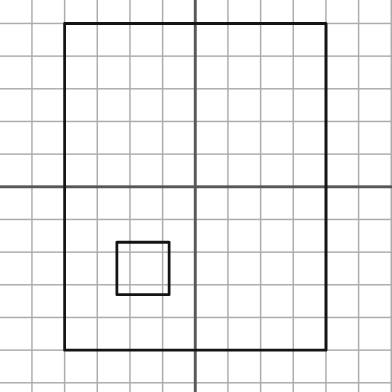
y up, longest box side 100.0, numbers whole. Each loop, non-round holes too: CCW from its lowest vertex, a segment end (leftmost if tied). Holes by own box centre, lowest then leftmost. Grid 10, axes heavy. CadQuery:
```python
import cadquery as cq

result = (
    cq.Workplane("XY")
    .moveTo(-40.0, -50.0)
    .lineTo(40.0, -50.0)
    .lineTo(40.0, 50.0)
    .lineTo(-40.0, 50.0)
    .close()
    .moveTo(-24.0, -33.0)
    .lineTo(-8.0, -33.0)
    .lineTo(-8.0, -17.0)
    .lineTo(-24.0, -17.0)
    .close()
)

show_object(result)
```